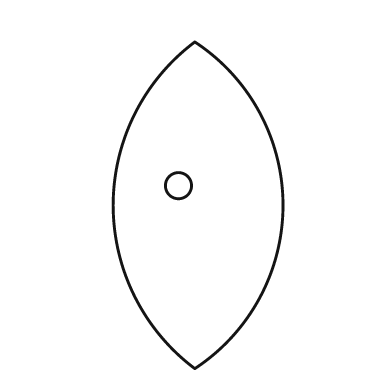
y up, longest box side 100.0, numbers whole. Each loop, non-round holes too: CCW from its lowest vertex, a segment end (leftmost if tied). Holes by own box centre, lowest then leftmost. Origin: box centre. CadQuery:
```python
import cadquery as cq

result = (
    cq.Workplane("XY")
    .moveTo(-1.0, -50.0)
    .threePointArc((26.0, 0.0), (-1.0, 50.0))
    .threePointArc((-26.0, 0.0), (-1.0, -50.0))
    .close()
    .moveTo(-6.0, 6.0)
    .circle(4.0)
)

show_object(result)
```